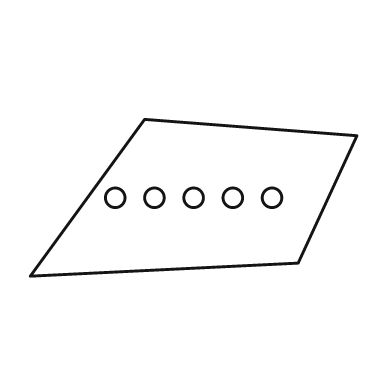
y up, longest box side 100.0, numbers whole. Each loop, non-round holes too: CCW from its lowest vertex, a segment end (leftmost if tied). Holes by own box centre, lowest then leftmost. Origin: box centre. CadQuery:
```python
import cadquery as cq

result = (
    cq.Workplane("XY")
    .moveTo(-50.0, -24.0)
    .lineTo(32.0, -20.0)
    .lineTo(50.0, 19.0)
    .lineTo(-15.0, 24.0)
    .close()
    .moveTo(-24.0, 0.0)
    .circle(3.0)
    .moveTo(-12.0, 0.0)
    .circle(3.0)
    .moveTo(0.0, 0.0)
    .circle(3.0)
    .moveTo(12.0, 0.0)
    .circle(3.0)
    .moveTo(24.0, 0.0)
    .circle(3.0)
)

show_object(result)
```